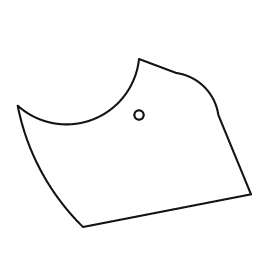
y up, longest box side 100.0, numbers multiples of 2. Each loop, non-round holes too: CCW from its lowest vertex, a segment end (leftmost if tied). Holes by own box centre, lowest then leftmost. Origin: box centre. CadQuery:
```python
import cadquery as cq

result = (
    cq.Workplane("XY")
    .moveTo(-22.0, -36.0)
    .lineTo(50.0, -22.0)
    .lineTo(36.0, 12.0)
    .threePointArc((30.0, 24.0), (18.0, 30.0))
    .lineTo(2.0, 36.0)
    .threePointArc((-18.0, 10.0), (-50.0, 16.0))
    .threePointArc((-40.0, -12.0), (-22.0, -36.0))
    .close()
    .moveTo(2.0, 12.0)
    .circle(2.0)
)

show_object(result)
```